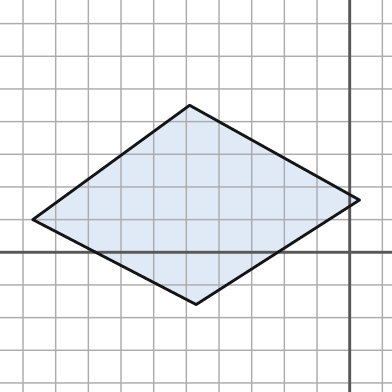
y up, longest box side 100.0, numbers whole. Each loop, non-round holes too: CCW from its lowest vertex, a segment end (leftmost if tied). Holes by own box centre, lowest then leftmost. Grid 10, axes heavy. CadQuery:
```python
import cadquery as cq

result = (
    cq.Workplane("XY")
    .moveTo(-47.0, -16.0)
    .lineTo(3.0, 16.0)
    .lineTo(-49.0, 45.0)
    .lineTo(-97.0, 10.0)
    .close()
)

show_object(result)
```